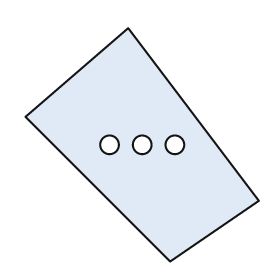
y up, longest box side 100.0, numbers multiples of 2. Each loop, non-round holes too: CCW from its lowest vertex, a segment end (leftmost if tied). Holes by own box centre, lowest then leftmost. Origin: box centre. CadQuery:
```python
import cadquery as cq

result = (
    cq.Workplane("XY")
    .moveTo(12.0, -50.0)
    .lineTo(50.0, -24.0)
    .lineTo(-6.0, 50.0)
    .lineTo(-50.0, 12.0)
    .close()
    .moveTo(-14.0, 0.0)
    .circle(4.0)
    .moveTo(0.0, 0.0)
    .circle(4.0)
    .moveTo(14.0, 0.0)
    .circle(4.0)
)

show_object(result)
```